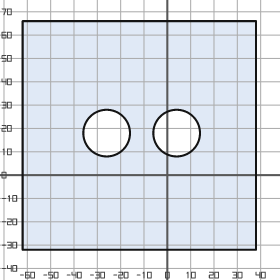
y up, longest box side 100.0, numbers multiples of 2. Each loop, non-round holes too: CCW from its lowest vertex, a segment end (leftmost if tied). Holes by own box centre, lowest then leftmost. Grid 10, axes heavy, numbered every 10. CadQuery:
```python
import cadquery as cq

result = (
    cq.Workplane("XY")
    .moveTo(-62.0, -32.0)
    .lineTo(38.0, -32.0)
    .lineTo(38.0, 66.0)
    .lineTo(-62.0, 66.0)
    .close()
    .moveTo(-26.0, 18.0)
    .circle(10.0)
    .moveTo(4.0, 18.0)
    .circle(10.0)
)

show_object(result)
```